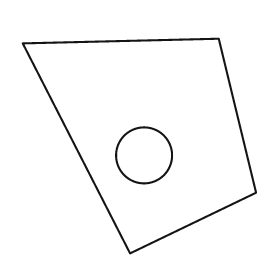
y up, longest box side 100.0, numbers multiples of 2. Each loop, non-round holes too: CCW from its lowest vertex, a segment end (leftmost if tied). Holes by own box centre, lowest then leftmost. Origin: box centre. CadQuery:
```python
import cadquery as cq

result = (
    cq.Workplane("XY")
    .moveTo(-4.0, -46.0)
    .lineTo(50.0, -20.0)
    .lineTo(34.0, 46.0)
    .lineTo(-50.0, 44.0)
    .close()
    .moveTo(2.0, -4.0)
    .circle(12.0)
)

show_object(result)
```